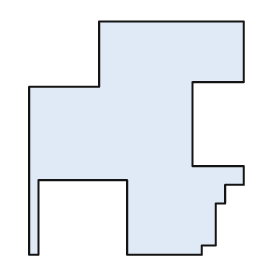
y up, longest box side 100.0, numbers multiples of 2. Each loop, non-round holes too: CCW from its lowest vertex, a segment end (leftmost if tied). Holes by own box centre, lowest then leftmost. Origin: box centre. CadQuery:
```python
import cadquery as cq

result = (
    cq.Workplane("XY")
    .moveTo(-46.0, -50.0)
    .lineTo(-42.0, -50.0)
    .lineTo(-42.0, -18.0)
    .lineTo(-4.0, -18.0)
    .lineTo(-4.0, -50.0)
    .lineTo(28.0, -50.0)
    .lineTo(28.0, -46.0)
    .lineTo(34.0, -46.0)
    .lineTo(34.0, -28.0)
    .lineTo(38.0, -28.0)
    .lineTo(38.0, -20.0)
    .lineTo(46.0, -20.0)
    .lineTo(46.0, -12.0)
    .lineTo(24.0, -12.0)
    .lineTo(24.0, 24.0)
    .lineTo(46.0, 24.0)
    .lineTo(46.0, 50.0)
    .lineTo(-16.0, 50.0)
    .lineTo(-16.0, 22.0)
    .lineTo(-46.0, 22.0)
    .close()
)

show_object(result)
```